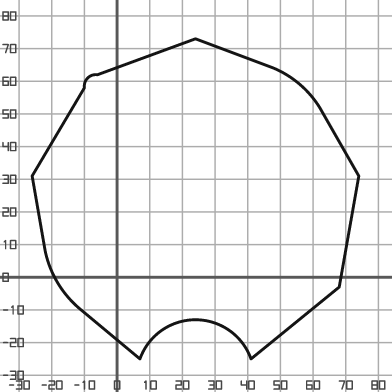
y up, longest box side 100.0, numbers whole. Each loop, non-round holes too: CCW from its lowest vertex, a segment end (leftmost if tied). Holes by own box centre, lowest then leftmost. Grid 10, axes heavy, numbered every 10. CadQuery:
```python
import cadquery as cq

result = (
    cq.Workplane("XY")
    .moveTo(7.0, -25.0)
    .threePointArc((24.0, -13.0), (41.0, -25.0))
    .lineTo(68.0, -3.0)
    .lineTo(74.0, 31.0)
    .lineTo(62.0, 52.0)
    .threePointArc((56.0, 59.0), (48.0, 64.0))
    .lineTo(24.0, 73.0)
    .lineTo(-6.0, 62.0)
    .threePointArc((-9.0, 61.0), (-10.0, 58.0))
    .lineTo(-26.0, 31.0)
    .lineTo(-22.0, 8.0)
    .threePointArc((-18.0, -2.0), (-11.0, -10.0))
    .close()
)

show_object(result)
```